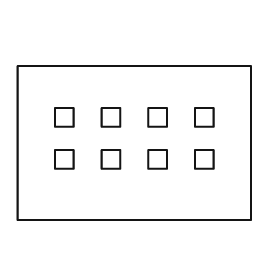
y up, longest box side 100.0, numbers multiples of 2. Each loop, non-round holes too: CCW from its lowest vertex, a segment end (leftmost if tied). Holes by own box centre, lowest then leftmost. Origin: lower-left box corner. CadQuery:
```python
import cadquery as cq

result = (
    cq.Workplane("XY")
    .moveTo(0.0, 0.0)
    .lineTo(100.0, 0.0)
    .lineTo(100.0, 66.0)
    .lineTo(0.0, 66.0)
    .close()
    .moveTo(16.0, 22.0)
    .lineTo(24.0, 22.0)
    .lineTo(24.0, 30.0)
    .lineTo(16.0, 30.0)
    .close()
    .moveTo(36.0, 22.0)
    .lineTo(44.0, 22.0)
    .lineTo(44.0, 30.0)
    .lineTo(36.0, 30.0)
    .close()
    .moveTo(56.0, 22.0)
    .lineTo(64.0, 22.0)
    .lineTo(64.0, 30.0)
    .lineTo(56.0, 30.0)
    .close()
    .moveTo(76.0, 22.0)
    .lineTo(84.0, 22.0)
    .lineTo(84.0, 30.0)
    .lineTo(76.0, 30.0)
    .close()
    .moveTo(16.0, 40.0)
    .lineTo(24.0, 40.0)
    .lineTo(24.0, 48.0)
    .lineTo(16.0, 48.0)
    .close()
    .moveTo(36.0, 40.0)
    .lineTo(44.0, 40.0)
    .lineTo(44.0, 48.0)
    .lineTo(36.0, 48.0)
    .close()
    .moveTo(56.0, 40.0)
    .lineTo(64.0, 40.0)
    .lineTo(64.0, 48.0)
    .lineTo(56.0, 48.0)
    .close()
    .moveTo(76.0, 40.0)
    .lineTo(84.0, 40.0)
    .lineTo(84.0, 48.0)
    .lineTo(76.0, 48.0)
    .close()
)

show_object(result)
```